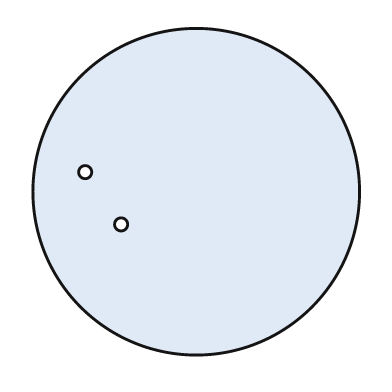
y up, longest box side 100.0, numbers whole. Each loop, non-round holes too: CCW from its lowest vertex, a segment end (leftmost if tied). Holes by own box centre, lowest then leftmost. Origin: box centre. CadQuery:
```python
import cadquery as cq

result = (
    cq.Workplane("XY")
    .moveTo(0.0, 0.0)
    .circle(50.0)
    .moveTo(-23.0, -10.0)
    .circle(2.0)
    .moveTo(-34.0, 6.0)
    .circle(2.0)
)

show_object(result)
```